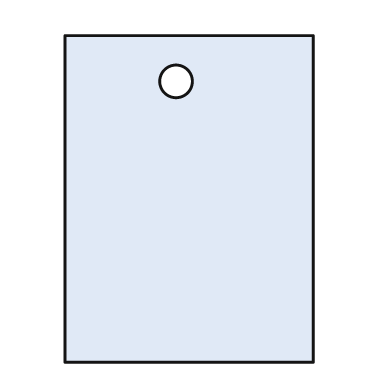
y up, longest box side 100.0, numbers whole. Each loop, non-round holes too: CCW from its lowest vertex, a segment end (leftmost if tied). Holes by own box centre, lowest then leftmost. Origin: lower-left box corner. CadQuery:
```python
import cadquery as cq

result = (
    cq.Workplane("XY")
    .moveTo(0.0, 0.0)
    .lineTo(76.0, 0.0)
    .lineTo(76.0, 100.0)
    .lineTo(0.0, 100.0)
    .close()
    .moveTo(34.0, 86.0)
    .circle(5.0)
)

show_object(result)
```